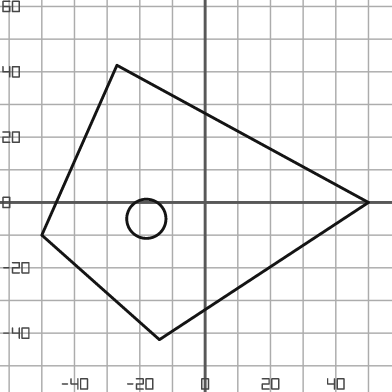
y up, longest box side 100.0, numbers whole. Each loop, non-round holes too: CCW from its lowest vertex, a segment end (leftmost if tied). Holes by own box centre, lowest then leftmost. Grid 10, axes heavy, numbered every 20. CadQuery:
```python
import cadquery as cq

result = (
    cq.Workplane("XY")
    .moveTo(-14.0, -42.0)
    .lineTo(50.0, 0.0)
    .lineTo(-27.0, 42.0)
    .lineTo(-50.0, -10.0)
    .close()
    .moveTo(-18.0, -5.0)
    .circle(6.0)
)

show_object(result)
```